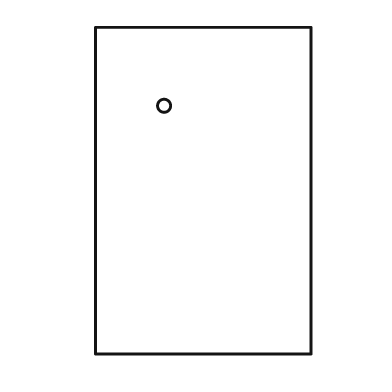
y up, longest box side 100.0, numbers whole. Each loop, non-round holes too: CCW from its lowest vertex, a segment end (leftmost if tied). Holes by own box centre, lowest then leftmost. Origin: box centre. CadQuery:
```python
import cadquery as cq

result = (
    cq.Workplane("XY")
    .moveTo(-33.0, -50.0)
    .lineTo(33.0, -50.0)
    .lineTo(33.0, 50.0)
    .lineTo(-33.0, 50.0)
    .close()
    .moveTo(-12.0, 26.0)
    .circle(2.0)
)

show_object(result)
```